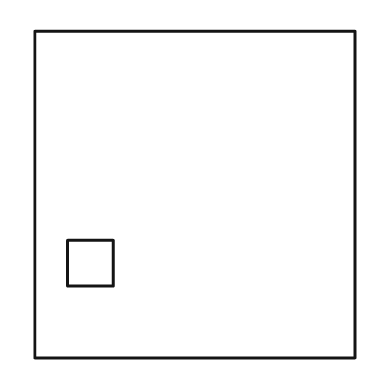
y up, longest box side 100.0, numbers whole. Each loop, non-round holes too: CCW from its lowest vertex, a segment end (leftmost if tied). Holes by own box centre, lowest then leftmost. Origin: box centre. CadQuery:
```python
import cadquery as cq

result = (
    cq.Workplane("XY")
    .moveTo(-49.0, -50.0)
    .lineTo(49.0, -50.0)
    .lineTo(49.0, 50.0)
    .lineTo(-49.0, 50.0)
    .close()
    .moveTo(-39.0, -28.0)
    .lineTo(-25.0, -28.0)
    .lineTo(-25.0, -14.0)
    .lineTo(-39.0, -14.0)
    .close()
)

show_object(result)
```